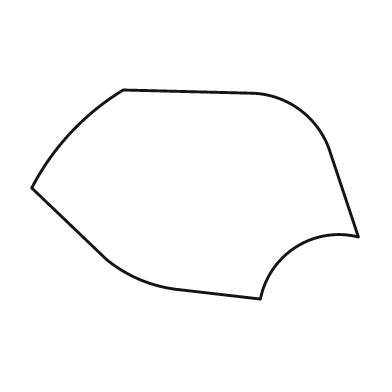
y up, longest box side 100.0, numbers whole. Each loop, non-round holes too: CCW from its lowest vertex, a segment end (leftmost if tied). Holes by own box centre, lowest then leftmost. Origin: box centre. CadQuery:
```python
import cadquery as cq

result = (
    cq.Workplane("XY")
    .moveTo(20.0, -32.0)
    .threePointArc((31.0, -16.0), (50.0, -13.0))
    .lineTo(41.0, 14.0)
    .threePointArc((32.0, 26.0), (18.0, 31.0))
    .lineTo(-22.0, 32.0)
    .threePointArc((-38.0, 19.0), (-50.0, 2.0))
    .lineTo(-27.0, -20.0)
    .threePointArc((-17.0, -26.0), (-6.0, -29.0))
    .close()
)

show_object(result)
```